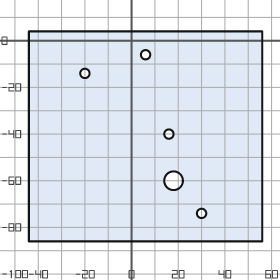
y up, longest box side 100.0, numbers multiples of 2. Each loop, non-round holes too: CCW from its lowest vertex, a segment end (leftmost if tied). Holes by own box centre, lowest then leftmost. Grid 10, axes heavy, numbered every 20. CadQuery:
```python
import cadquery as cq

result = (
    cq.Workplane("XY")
    .moveTo(-44.0, -86.0)
    .lineTo(56.0, -86.0)
    .lineTo(56.0, 4.0)
    .lineTo(-44.0, 4.0)
    .close()
    .moveTo(30.0, -74.0)
    .circle(2.0)
    .moveTo(18.0, -60.0)
    .circle(4.0)
    .moveTo(16.0, -40.0)
    .circle(2.0)
    .moveTo(-20.0, -14.0)
    .circle(2.0)
    .moveTo(6.0, -6.0)
    .circle(2.0)
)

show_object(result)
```